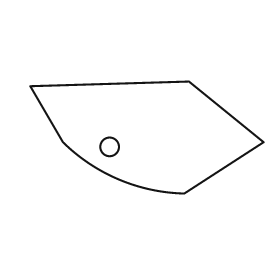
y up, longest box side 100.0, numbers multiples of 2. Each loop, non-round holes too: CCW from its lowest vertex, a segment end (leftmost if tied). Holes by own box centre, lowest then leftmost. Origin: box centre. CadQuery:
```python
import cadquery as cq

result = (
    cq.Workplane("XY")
    .moveTo(16.0, -24.0)
    .lineTo(50.0, -2.0)
    .lineTo(18.0, 24.0)
    .lineTo(-50.0, 22.0)
    .lineTo(-36.0, -2.0)
    .threePointArc((-12.0, -18.0), (16.0, -24.0))
    .close()
    .moveTo(-16.0, -4.0)
    .circle(4.0)
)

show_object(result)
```